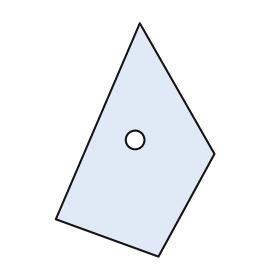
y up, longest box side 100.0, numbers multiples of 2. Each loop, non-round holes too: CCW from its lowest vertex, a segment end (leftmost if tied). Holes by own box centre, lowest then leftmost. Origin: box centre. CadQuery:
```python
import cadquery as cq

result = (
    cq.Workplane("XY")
    .moveTo(10.0, -50.0)
    .lineTo(34.0, -6.0)
    .lineTo(2.0, 50.0)
    .lineTo(-34.0, -34.0)
    .close()
    .moveTo(0.0, 0.0)
    .circle(4.0)
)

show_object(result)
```